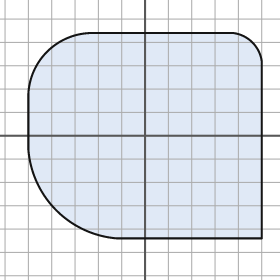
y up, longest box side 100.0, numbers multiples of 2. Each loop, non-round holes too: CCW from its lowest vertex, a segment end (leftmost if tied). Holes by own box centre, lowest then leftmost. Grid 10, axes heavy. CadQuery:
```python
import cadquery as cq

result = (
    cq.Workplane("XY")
    .moveTo(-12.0, -44.0)
    .lineTo(50.0, -44.0)
    .lineTo(50.0, 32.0)
    .threePointArc((46.0, 40.0), (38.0, 44.0))
    .lineTo(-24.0, 44.0)
    .threePointArc((-42.0, 36.0), (-50.0, 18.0))
    .lineTo(-50.0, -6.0)
    .threePointArc((-38.0, -32.0), (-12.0, -44.0))
    .close()
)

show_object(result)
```